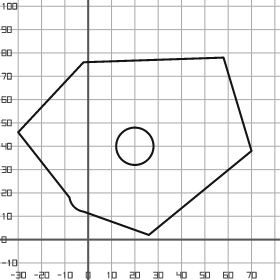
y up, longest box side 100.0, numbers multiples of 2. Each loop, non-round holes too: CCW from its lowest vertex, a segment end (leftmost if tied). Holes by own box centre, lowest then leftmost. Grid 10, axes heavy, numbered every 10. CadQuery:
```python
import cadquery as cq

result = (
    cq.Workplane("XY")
    .moveTo(26.0, 2.0)
    .lineTo(70.0, 38.0)
    .lineTo(58.0, 78.0)
    .lineTo(-2.0, 76.0)
    .lineTo(-30.0, 46.0)
    .lineTo(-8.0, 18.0)
    .threePointArc((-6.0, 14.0), (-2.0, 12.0))
    .close()
    .moveTo(20.0, 40.0)
    .circle(8.0)
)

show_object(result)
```